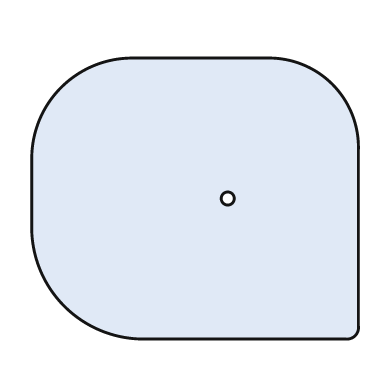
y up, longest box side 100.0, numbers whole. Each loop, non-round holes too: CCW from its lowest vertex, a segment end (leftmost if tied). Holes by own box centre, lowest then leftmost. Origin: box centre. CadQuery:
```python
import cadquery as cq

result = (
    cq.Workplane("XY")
    .moveTo(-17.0, -43.0)
    .lineTo(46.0, -43.0)
    .threePointArc((49.0, -42.0), (50.0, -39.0))
    .lineTo(50.0, 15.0)
    .threePointArc((42.0, 35.0), (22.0, 43.0))
    .lineTo(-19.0, 43.0)
    .threePointArc((-41.0, 34.0), (-50.0, 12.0))
    .lineTo(-50.0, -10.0)
    .threePointArc((-40.0, -33.0), (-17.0, -43.0))
    .close()
    .moveTo(10.0, 0.0)
    .circle(2.0)
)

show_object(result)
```